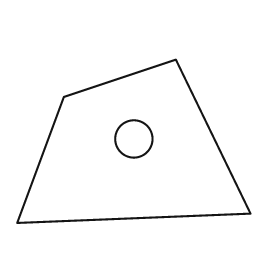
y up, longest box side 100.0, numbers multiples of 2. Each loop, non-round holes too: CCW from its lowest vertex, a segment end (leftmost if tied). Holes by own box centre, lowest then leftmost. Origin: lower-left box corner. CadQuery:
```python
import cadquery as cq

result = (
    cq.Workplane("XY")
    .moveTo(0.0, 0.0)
    .lineTo(100.0, 4.0)
    .lineTo(68.0, 70.0)
    .lineTo(20.0, 54.0)
    .close()
    .moveTo(50.0, 36.0)
    .circle(8.0)
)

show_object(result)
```